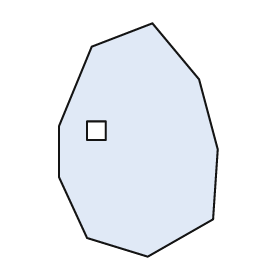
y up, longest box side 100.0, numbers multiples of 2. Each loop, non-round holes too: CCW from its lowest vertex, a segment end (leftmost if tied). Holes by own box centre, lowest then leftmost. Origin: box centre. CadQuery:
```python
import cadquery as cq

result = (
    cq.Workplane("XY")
    .moveTo(4.0, -50.0)
    .lineTo(32.0, -34.0)
    .lineTo(34.0, -4.0)
    .lineTo(26.0, 26.0)
    .lineTo(6.0, 50.0)
    .lineTo(-20.0, 40.0)
    .lineTo(-34.0, 6.0)
    .lineTo(-34.0, -16.0)
    .lineTo(-22.0, -42.0)
    .close()
    .moveTo(-22.0, 0.0)
    .lineTo(-14.0, 0.0)
    .lineTo(-14.0, 8.0)
    .lineTo(-22.0, 8.0)
    .close()
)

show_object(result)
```